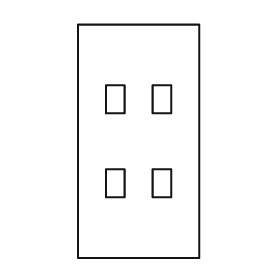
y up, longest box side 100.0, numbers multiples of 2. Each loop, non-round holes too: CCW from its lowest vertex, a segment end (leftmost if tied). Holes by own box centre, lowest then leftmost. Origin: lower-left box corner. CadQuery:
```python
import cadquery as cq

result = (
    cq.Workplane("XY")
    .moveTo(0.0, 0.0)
    .lineTo(52.0, 0.0)
    .lineTo(52.0, 100.0)
    .lineTo(0.0, 100.0)
    .close()
    .moveTo(12.0, 26.0)
    .lineTo(20.0, 26.0)
    .lineTo(20.0, 38.0)
    .lineTo(12.0, 38.0)
    .close()
    .moveTo(32.0, 26.0)
    .lineTo(40.0, 26.0)
    .lineTo(40.0, 38.0)
    .lineTo(32.0, 38.0)
    .close()
    .moveTo(12.0, 62.0)
    .lineTo(20.0, 62.0)
    .lineTo(20.0, 74.0)
    .lineTo(12.0, 74.0)
    .close()
    .moveTo(32.0, 62.0)
    .lineTo(40.0, 62.0)
    .lineTo(40.0, 74.0)
    .lineTo(32.0, 74.0)
    .close()
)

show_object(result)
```